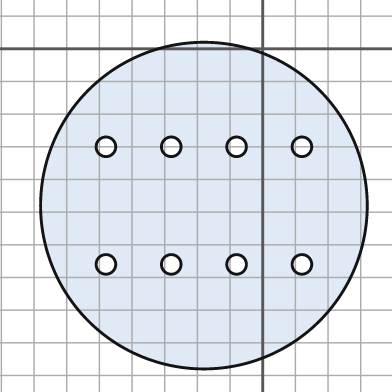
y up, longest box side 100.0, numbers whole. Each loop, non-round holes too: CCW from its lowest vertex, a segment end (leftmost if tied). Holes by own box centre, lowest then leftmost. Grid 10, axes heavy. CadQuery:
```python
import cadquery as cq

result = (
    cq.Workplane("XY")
    .moveTo(-18.0, -48.0)
    .circle(50.0)
    .moveTo(-48.0, -66.0)
    .circle(3.0)
    .moveTo(-28.0, -66.0)
    .circle(3.0)
    .moveTo(-8.0, -66.0)
    .circle(3.0)
    .moveTo(12.0, -66.0)
    .circle(3.0)
    .moveTo(-48.0, -30.0)
    .circle(3.0)
    .moveTo(-28.0, -30.0)
    .circle(3.0)
    .moveTo(-8.0, -30.0)
    .circle(3.0)
    .moveTo(12.0, -30.0)
    .circle(3.0)
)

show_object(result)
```